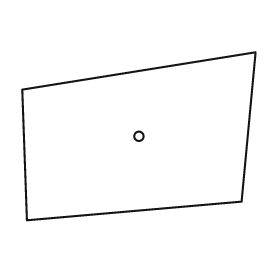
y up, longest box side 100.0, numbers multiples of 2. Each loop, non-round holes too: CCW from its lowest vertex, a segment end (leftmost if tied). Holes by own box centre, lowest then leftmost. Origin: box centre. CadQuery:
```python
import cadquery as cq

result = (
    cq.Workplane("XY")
    .moveTo(-48.0, -36.0)
    .lineTo(44.0, -28.0)
    .lineTo(50.0, 36.0)
    .lineTo(-50.0, 20.0)
    .close()
    .moveTo(0.0, 0.0)
    .circle(2.0)
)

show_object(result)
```